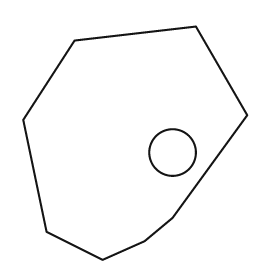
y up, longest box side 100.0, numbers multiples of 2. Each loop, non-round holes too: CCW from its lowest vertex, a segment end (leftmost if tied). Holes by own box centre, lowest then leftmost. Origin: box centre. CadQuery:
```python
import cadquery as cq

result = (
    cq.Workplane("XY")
    .moveTo(-14.0, -50.0)
    .lineTo(4.0, -42.0)
    .lineTo(16.0, -32.0)
    .lineTo(48.0, 12.0)
    .lineTo(26.0, 50.0)
    .lineTo(-26.0, 44.0)
    .lineTo(-48.0, 10.0)
    .lineTo(-38.0, -38.0)
    .close()
    .moveTo(16.0, -4.0)
    .circle(10.0)
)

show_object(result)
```